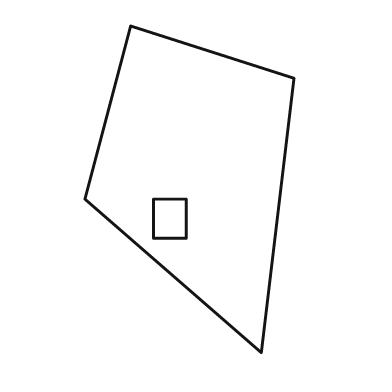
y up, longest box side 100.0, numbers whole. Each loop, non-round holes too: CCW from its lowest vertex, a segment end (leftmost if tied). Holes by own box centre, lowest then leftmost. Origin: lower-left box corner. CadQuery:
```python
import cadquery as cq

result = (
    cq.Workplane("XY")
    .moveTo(54.0, 0.0)
    .lineTo(64.0, 84.0)
    .lineTo(14.0, 100.0)
    .lineTo(0.0, 47.0)
    .close()
    .moveTo(21.0, 35.0)
    .lineTo(31.0, 35.0)
    .lineTo(31.0, 47.0)
    .lineTo(21.0, 47.0)
    .close()
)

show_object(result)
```